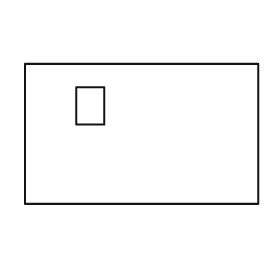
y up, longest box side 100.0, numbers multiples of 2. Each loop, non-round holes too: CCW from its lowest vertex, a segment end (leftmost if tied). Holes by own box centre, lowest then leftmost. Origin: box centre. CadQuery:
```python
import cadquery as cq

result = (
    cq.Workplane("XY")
    .moveTo(-50.0, -30.0)
    .lineTo(50.0, -30.0)
    .lineTo(50.0, 30.0)
    .lineTo(-50.0, 30.0)
    .close()
    .moveTo(-28.0, 4.0)
    .lineTo(-16.0, 4.0)
    .lineTo(-16.0, 20.0)
    .lineTo(-28.0, 20.0)
    .close()
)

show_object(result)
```